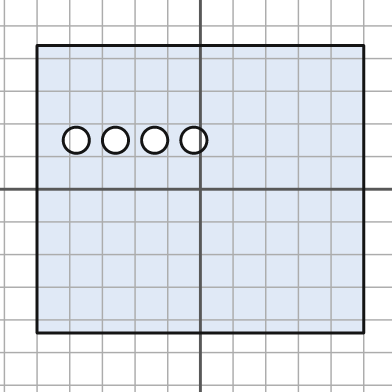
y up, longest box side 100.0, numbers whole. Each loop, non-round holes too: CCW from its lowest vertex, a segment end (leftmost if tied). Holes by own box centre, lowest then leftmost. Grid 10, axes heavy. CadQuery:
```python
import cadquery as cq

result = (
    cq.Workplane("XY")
    .moveTo(-50.0, -44.0)
    .lineTo(50.0, -44.0)
    .lineTo(50.0, 44.0)
    .lineTo(-50.0, 44.0)
    .close()
    .moveTo(-38.0, 15.0)
    .circle(4.0)
    .moveTo(-26.0, 15.0)
    .circle(4.0)
    .moveTo(-14.0, 15.0)
    .circle(4.0)
    .moveTo(-2.0, 15.0)
    .circle(4.0)
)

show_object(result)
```